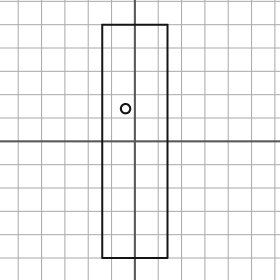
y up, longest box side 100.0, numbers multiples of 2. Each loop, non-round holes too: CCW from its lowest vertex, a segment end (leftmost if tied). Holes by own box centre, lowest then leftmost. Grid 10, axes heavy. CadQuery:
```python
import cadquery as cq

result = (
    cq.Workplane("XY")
    .moveTo(-14.0, -50.0)
    .lineTo(14.0, -50.0)
    .lineTo(14.0, 50.0)
    .lineTo(-14.0, 50.0)
    .close()
    .moveTo(-4.0, 14.0)
    .circle(2.0)
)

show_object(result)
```